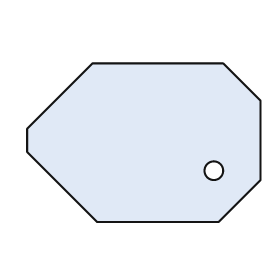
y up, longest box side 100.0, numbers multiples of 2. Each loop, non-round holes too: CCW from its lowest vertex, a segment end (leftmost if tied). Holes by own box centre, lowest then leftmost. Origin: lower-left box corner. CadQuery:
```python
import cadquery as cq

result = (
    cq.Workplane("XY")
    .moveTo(30.0, 0.0)
    .lineTo(82.0, 0.0)
    .lineTo(100.0, 18.0)
    .lineTo(100.0, 52.0)
    .lineTo(84.0, 68.0)
    .lineTo(28.0, 68.0)
    .lineTo(0.0, 40.0)
    .lineTo(0.0, 30.0)
    .close()
    .moveTo(80.0, 22.0)
    .circle(4.0)
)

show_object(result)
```